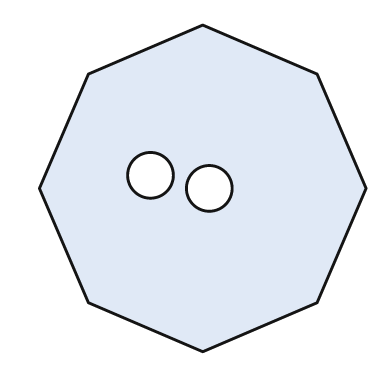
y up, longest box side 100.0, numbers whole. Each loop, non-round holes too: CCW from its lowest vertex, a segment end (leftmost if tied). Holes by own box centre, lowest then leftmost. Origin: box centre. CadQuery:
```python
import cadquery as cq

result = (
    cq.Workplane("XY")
    .moveTo(0.0, -50.0)
    .lineTo(35.0, -35.0)
    .lineTo(50.0, 0.0)
    .lineTo(35.0, 35.0)
    .lineTo(0.0, 50.0)
    .lineTo(-35.0, 35.0)
    .lineTo(-50.0, 0.0)
    .lineTo(-35.0, -35.0)
    .close()
    .moveTo(2.0, 0.0)
    .circle(7.0)
    .moveTo(-16.0, 4.0)
    .circle(7.0)
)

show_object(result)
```